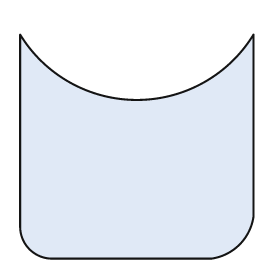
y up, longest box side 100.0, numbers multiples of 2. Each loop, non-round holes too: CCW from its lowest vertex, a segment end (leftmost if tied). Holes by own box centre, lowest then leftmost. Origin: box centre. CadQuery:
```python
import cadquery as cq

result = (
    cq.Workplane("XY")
    .moveTo(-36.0, -48.0)
    .lineTo(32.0, -48.0)
    .threePointArc((44.0, -42.0), (50.0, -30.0))
    .lineTo(50.0, 48.0)
    .threePointArc((0.0, 20.0), (-50.0, 48.0))
    .lineTo(-50.0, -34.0)
    .threePointArc((-46.0, -44.0), (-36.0, -48.0))
    .close()
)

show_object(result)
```